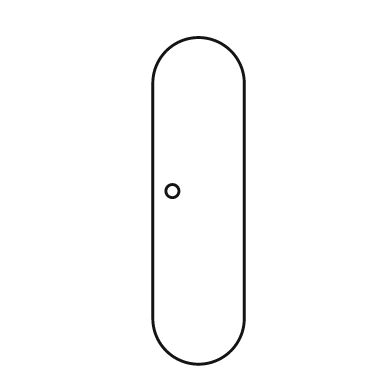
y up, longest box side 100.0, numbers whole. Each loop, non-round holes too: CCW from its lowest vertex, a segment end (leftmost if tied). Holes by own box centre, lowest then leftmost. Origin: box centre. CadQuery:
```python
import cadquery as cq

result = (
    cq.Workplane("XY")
    .moveTo(-14.0, -36.0)
    .threePointArc((0.0, -50.0), (14.0, -36.0))
    .lineTo(14.0, 36.0)
    .threePointArc((0.0, 50.0), (-14.0, 36.0))
    .close()
    .moveTo(-8.0, 3.0)
    .circle(2.0)
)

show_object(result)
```